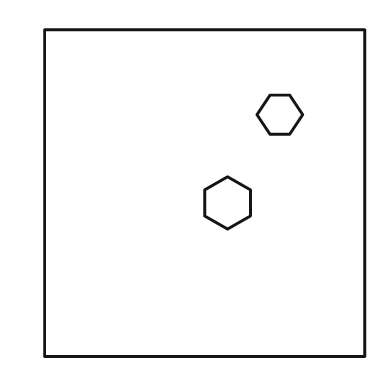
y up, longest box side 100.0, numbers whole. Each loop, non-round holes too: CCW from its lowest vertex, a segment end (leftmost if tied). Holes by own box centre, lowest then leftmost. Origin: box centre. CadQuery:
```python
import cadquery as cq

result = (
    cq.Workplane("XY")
    .moveTo(-49.0, -50.0)
    .lineTo(49.0, -50.0)
    .lineTo(49.0, 50.0)
    .lineTo(-49.0, 50.0)
    .close()
    .moveTo(7.0, -11.0)
    .lineTo(14.0, -7.0)
    .lineTo(14.0, 1.0)
    .lineTo(7.0, 5.0)
    .lineTo(0.0, 1.0)
    .lineTo(0.0, -7.0)
    .close()
    .moveTo(20.0, 18.0)
    .lineTo(26.0, 18.0)
    .lineTo(30.0, 24.0)
    .lineTo(26.0, 30.0)
    .lineTo(20.0, 30.0)
    .lineTo(16.0, 24.0)
    .close()
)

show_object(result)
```